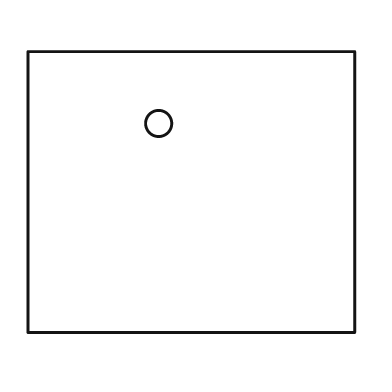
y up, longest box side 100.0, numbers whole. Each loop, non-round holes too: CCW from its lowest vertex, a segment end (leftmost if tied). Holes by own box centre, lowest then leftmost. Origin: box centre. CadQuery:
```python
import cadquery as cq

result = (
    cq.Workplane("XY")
    .moveTo(-50.0, -43.0)
    .lineTo(50.0, -43.0)
    .lineTo(50.0, 43.0)
    .lineTo(-50.0, 43.0)
    .close()
    .moveTo(-10.0, 21.0)
    .circle(4.0)
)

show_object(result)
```